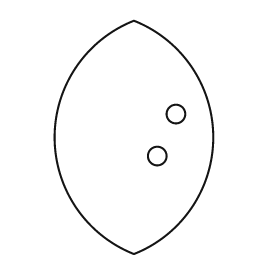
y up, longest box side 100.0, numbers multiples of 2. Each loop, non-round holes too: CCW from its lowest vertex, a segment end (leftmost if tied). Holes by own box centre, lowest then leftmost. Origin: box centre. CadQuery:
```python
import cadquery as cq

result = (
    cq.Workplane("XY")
    .moveTo(0.0, -50.0)
    .threePointArc((34.0, 0.0), (0.0, 50.0))
    .threePointArc((-34.0, 0.0), (0.0, -50.0))
    .close()
    .moveTo(10.0, -8.0)
    .circle(4.0)
    .moveTo(18.0, 10.0)
    .circle(4.0)
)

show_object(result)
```